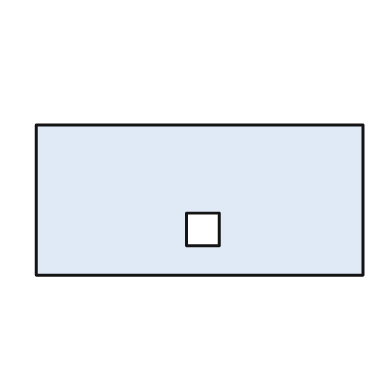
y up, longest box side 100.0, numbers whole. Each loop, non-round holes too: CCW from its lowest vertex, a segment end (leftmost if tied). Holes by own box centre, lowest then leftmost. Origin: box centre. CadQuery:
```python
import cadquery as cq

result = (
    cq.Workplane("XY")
    .moveTo(-50.0, -23.0)
    .lineTo(50.0, -23.0)
    .lineTo(50.0, 23.0)
    .lineTo(-50.0, 23.0)
    .close()
    .moveTo(-4.0, -14.0)
    .lineTo(6.0, -14.0)
    .lineTo(6.0, -4.0)
    .lineTo(-4.0, -4.0)
    .close()
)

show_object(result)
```